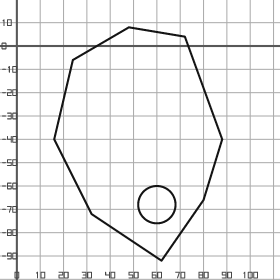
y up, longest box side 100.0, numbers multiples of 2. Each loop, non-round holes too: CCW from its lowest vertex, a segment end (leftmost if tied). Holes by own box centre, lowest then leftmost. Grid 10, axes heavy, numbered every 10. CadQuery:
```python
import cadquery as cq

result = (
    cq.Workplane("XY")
    .moveTo(62.0, -92.0)
    .lineTo(80.0, -66.0)
    .lineTo(88.0, -40.0)
    .lineTo(72.0, 4.0)
    .lineTo(48.0, 8.0)
    .lineTo(24.0, -6.0)
    .lineTo(16.0, -40.0)
    .lineTo(32.0, -72.0)
    .close()
    .moveTo(60.0, -68.0)
    .circle(8.0)
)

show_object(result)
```